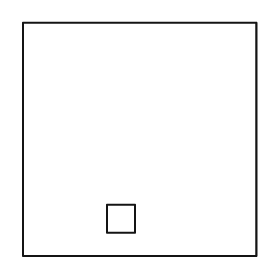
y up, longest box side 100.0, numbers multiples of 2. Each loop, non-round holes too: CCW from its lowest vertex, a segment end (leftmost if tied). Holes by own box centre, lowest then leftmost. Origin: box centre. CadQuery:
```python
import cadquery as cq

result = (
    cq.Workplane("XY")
    .moveTo(-50.0, -50.0)
    .lineTo(50.0, -50.0)
    .lineTo(50.0, 50.0)
    .lineTo(-50.0, 50.0)
    .close()
    .moveTo(-14.0, -40.0)
    .lineTo(-2.0, -40.0)
    .lineTo(-2.0, -28.0)
    .lineTo(-14.0, -28.0)
    .close()
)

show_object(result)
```